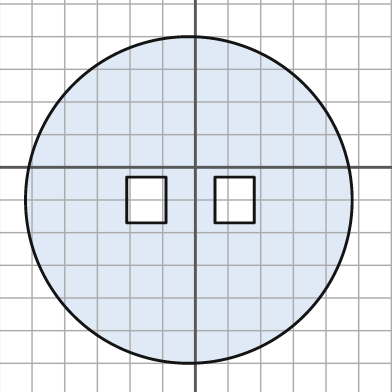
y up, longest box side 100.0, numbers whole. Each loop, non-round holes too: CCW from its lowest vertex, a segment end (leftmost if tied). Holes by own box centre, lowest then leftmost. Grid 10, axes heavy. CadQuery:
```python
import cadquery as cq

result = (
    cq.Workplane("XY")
    .moveTo(-2.0, -10.0)
    .circle(50.0)
    .moveTo(-21.0, -17.0)
    .lineTo(-9.0, -17.0)
    .lineTo(-9.0, -3.0)
    .lineTo(-21.0, -3.0)
    .close()
    .moveTo(6.0, -17.0)
    .lineTo(18.0, -17.0)
    .lineTo(18.0, -3.0)
    .lineTo(6.0, -3.0)
    .close()
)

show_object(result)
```